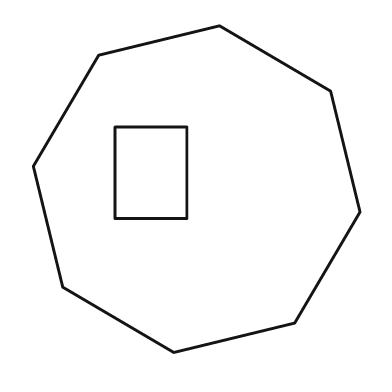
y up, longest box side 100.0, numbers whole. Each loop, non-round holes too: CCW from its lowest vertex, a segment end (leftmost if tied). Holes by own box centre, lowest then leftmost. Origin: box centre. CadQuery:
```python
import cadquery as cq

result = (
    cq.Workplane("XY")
    .moveTo(-7.0, -50.0)
    .lineTo(30.0, -41.0)
    .lineTo(50.0, -7.0)
    .lineTo(41.0, 30.0)
    .lineTo(7.0, 50.0)
    .lineTo(-30.0, 41.0)
    .lineTo(-50.0, 7.0)
    .lineTo(-41.0, -30.0)
    .close()
    .moveTo(-25.0, -9.0)
    .lineTo(-3.0, -9.0)
    .lineTo(-3.0, 19.0)
    .lineTo(-25.0, 19.0)
    .close()
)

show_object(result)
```